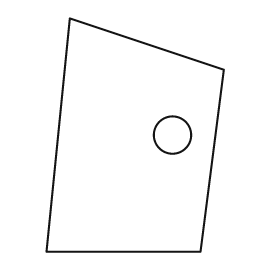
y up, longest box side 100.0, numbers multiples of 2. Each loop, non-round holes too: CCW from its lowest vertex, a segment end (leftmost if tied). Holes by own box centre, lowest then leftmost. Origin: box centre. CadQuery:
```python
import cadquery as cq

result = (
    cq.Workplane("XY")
    .moveTo(-38.0, -50.0)
    .lineTo(28.0, -50.0)
    .lineTo(38.0, 28.0)
    .lineTo(-28.0, 50.0)
    .close()
    .moveTo(16.0, 0.0)
    .circle(8.0)
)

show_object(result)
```